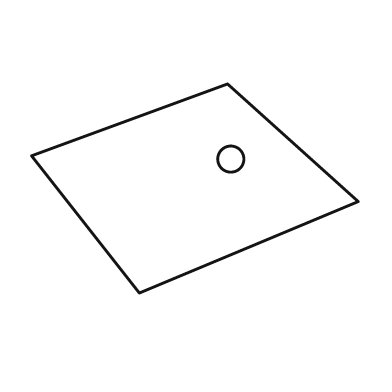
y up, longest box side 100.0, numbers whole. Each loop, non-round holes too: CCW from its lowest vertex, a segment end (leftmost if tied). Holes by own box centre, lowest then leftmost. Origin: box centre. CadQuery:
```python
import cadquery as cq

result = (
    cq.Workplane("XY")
    .moveTo(-17.0, -32.0)
    .lineTo(50.0, -4.0)
    .lineTo(10.0, 32.0)
    .lineTo(-50.0, 10.0)
    .close()
    .moveTo(11.0, 9.0)
    .circle(4.0)
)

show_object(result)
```